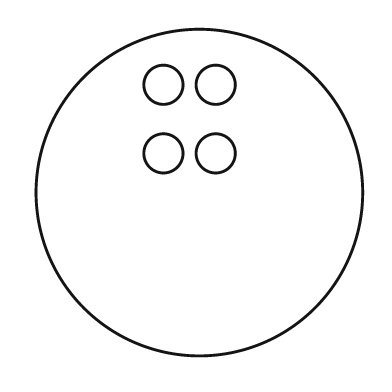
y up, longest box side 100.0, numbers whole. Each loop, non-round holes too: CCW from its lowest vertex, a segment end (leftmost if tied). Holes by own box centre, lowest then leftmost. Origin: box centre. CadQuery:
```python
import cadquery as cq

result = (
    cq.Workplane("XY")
    .moveTo(0.0, 0.0)
    .circle(50.0)
    .moveTo(-11.0, 12.0)
    .circle(6.0)
    .moveTo(5.0, 12.0)
    .circle(6.0)
    .moveTo(-11.0, 33.0)
    .circle(6.0)
    .moveTo(5.0, 33.0)
    .circle(6.0)
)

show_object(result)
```